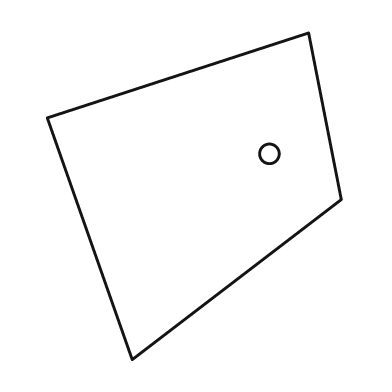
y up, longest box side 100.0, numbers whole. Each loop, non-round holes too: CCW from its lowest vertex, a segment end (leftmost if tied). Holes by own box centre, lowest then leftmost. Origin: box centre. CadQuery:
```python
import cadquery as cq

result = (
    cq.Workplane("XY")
    .moveTo(-19.0, -50.0)
    .lineTo(45.0, -1.0)
    .lineTo(35.0, 50.0)
    .lineTo(-45.0, 24.0)
    .close()
    .moveTo(23.0, 13.0)
    .circle(3.0)
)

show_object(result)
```